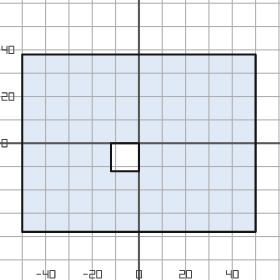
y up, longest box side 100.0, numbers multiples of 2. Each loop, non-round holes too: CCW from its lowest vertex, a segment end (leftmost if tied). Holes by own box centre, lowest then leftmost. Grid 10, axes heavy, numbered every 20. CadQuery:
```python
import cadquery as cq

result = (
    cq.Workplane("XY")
    .moveTo(-50.0, -38.0)
    .lineTo(50.0, -38.0)
    .lineTo(50.0, 38.0)
    .lineTo(-50.0, 38.0)
    .close()
    .moveTo(-12.0, -12.0)
    .lineTo(0.0, -12.0)
    .lineTo(0.0, 0.0)
    .lineTo(-12.0, 0.0)
    .close()
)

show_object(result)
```